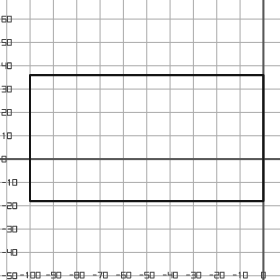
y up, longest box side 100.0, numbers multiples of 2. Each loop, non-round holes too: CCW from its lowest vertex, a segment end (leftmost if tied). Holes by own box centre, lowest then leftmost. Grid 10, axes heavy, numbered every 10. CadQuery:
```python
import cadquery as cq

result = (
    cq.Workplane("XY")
    .moveTo(-100.0, -18.0)
    .lineTo(0.0, -18.0)
    .lineTo(0.0, 36.0)
    .lineTo(-100.0, 36.0)
    .close()
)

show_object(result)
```